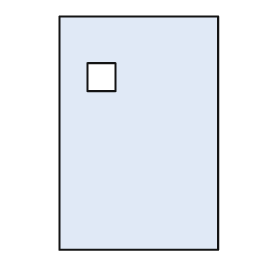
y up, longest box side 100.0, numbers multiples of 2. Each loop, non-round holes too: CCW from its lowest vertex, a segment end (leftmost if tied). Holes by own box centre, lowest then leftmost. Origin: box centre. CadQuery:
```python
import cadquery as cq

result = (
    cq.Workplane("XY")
    .moveTo(-34.0, -50.0)
    .lineTo(34.0, -50.0)
    .lineTo(34.0, 50.0)
    .lineTo(-34.0, 50.0)
    .close()
    .moveTo(-22.0, 18.0)
    .lineTo(-10.0, 18.0)
    .lineTo(-10.0, 30.0)
    .lineTo(-22.0, 30.0)
    .close()
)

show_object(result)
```